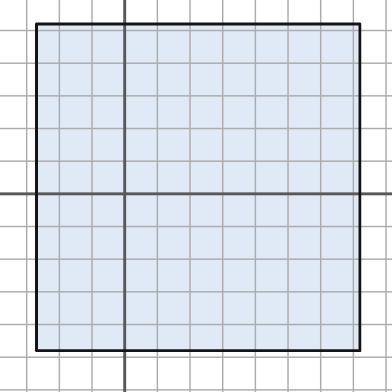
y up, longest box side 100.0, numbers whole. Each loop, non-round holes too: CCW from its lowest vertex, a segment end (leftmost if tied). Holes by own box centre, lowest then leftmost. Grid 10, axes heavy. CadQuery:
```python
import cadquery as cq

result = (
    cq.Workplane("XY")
    .moveTo(-27.0, -48.0)
    .lineTo(72.0, -48.0)
    .lineTo(72.0, 52.0)
    .lineTo(-27.0, 52.0)
    .close()
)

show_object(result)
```